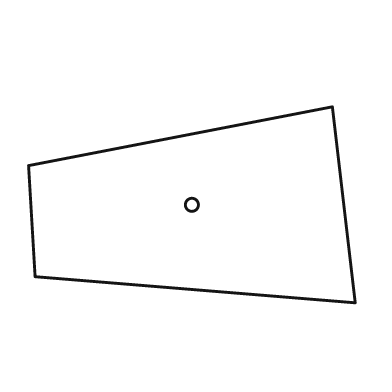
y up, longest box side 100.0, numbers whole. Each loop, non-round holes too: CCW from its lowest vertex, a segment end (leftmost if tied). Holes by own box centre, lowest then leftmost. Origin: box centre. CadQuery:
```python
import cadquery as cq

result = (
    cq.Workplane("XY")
    .moveTo(50.0, -30.0)
    .lineTo(43.0, 30.0)
    .lineTo(-50.0, 12.0)
    .lineTo(-48.0, -22.0)
    .close()
    .moveTo(0.0, 0.0)
    .circle(2.0)
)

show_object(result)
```